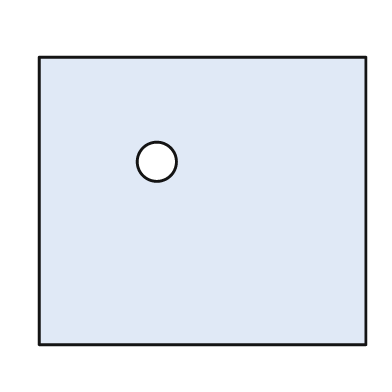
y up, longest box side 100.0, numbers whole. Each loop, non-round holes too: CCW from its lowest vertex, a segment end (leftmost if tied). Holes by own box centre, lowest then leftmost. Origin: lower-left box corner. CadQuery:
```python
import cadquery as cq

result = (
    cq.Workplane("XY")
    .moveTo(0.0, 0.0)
    .lineTo(100.0, 0.0)
    .lineTo(100.0, 88.0)
    .lineTo(0.0, 88.0)
    .close()
    .moveTo(36.0, 56.0)
    .circle(6.0)
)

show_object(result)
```